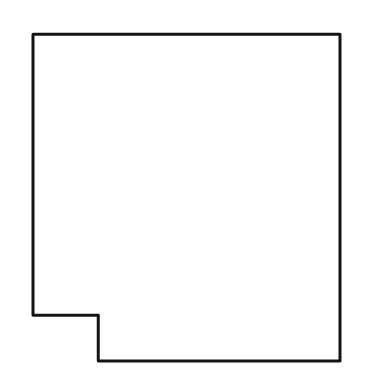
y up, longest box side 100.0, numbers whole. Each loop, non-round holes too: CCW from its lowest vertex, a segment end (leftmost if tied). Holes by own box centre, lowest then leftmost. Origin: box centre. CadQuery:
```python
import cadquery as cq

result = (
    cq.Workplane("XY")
    .moveTo(-27.0, -50.0)
    .lineTo(47.0, -50.0)
    .lineTo(47.0, 50.0)
    .lineTo(-47.0, 50.0)
    .lineTo(-47.0, -36.0)
    .lineTo(-27.0, -36.0)
    .close()
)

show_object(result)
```